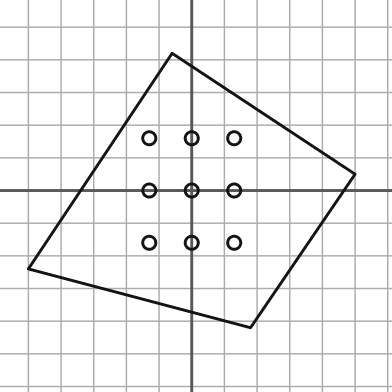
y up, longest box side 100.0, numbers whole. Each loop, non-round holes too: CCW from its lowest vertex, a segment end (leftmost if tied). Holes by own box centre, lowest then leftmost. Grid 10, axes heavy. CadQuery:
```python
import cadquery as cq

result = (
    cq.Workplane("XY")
    .moveTo(18.0, -42.0)
    .lineTo(50.0, 5.0)
    .lineTo(-6.0, 42.0)
    .lineTo(-50.0, -24.0)
    .close()
    .moveTo(-13.0, -16.0)
    .circle(2.0)
    .moveTo(0.0, -16.0)
    .circle(2.0)
    .moveTo(13.0, -16.0)
    .circle(2.0)
    .moveTo(-13.0, 0.0)
    .circle(2.0)
    .moveTo(0.0, 0.0)
    .circle(2.0)
    .moveTo(13.0, 0.0)
    .circle(2.0)
    .moveTo(-13.0, 16.0)
    .circle(2.0)
    .moveTo(0.0, 16.0)
    .circle(2.0)
    .moveTo(13.0, 16.0)
    .circle(2.0)
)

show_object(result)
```